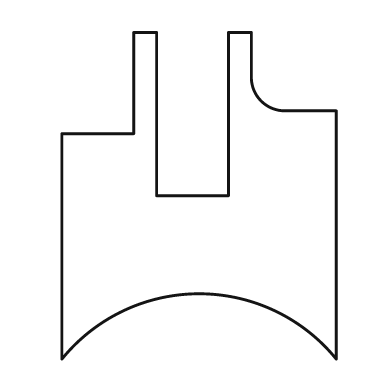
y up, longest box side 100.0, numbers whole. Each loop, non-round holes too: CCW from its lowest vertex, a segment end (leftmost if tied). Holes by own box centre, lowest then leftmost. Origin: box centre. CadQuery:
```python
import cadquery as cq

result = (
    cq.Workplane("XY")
    .moveTo(-42.0, -50.0)
    .threePointArc((0.0, -30.0), (42.0, -50.0))
    .lineTo(42.0, 26.0)
    .lineTo(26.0, 26.0)
    .threePointArc((19.0, 29.0), (16.0, 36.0))
    .lineTo(16.0, 50.0)
    .lineTo(9.0, 50.0)
    .lineTo(9.0, 0.0)
    .lineTo(-13.0, 0.0)
    .lineTo(-13.0, 50.0)
    .lineTo(-20.0, 50.0)
    .lineTo(-20.0, 19.0)
    .lineTo(-42.0, 19.0)
    .close()
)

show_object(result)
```